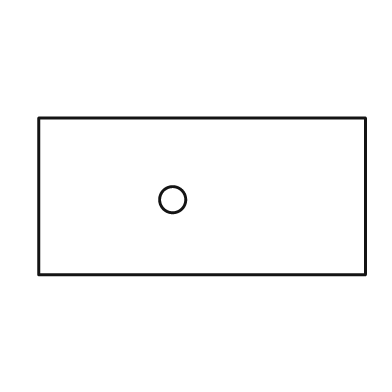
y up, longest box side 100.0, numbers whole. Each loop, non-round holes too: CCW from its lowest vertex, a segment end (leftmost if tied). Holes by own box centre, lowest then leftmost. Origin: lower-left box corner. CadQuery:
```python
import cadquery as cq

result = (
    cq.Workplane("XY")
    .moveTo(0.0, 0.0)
    .lineTo(100.0, 0.0)
    .lineTo(100.0, 48.0)
    .lineTo(0.0, 48.0)
    .close()
    .moveTo(41.0, 23.0)
    .circle(4.0)
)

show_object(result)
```